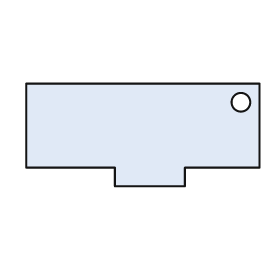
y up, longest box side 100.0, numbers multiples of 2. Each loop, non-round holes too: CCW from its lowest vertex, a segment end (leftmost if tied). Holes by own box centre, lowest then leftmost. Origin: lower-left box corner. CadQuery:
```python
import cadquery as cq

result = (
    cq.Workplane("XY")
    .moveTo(38.0, 0.0)
    .lineTo(68.0, 0.0)
    .lineTo(68.0, 8.0)
    .lineTo(100.0, 8.0)
    .lineTo(100.0, 44.0)
    .lineTo(0.0, 44.0)
    .lineTo(0.0, 8.0)
    .lineTo(38.0, 8.0)
    .close()
    .moveTo(92.0, 36.0)
    .circle(4.0)
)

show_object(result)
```